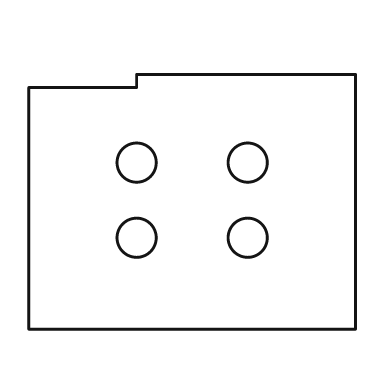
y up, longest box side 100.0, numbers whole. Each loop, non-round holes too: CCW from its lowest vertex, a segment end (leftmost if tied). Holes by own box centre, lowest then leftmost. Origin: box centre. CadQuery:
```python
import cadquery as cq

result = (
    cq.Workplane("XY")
    .moveTo(-50.0, -39.0)
    .lineTo(50.0, -39.0)
    .lineTo(50.0, 39.0)
    .lineTo(-17.0, 39.0)
    .lineTo(-17.0, 35.0)
    .lineTo(-50.0, 35.0)
    .close()
    .moveTo(-17.0, -11.0)
    .circle(6.0)
    .moveTo(17.0, -11.0)
    .circle(6.0)
    .moveTo(-17.0, 12.0)
    .circle(6.0)
    .moveTo(17.0, 12.0)
    .circle(6.0)
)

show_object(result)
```